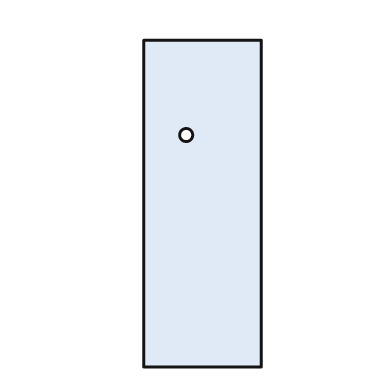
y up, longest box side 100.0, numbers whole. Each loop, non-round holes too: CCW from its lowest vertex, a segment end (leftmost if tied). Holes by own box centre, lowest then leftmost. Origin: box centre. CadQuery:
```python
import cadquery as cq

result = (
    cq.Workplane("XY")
    .moveTo(-18.0, -50.0)
    .lineTo(18.0, -50.0)
    .lineTo(18.0, 50.0)
    .lineTo(-18.0, 50.0)
    .close()
    .moveTo(-5.0, 21.0)
    .circle(2.0)
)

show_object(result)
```